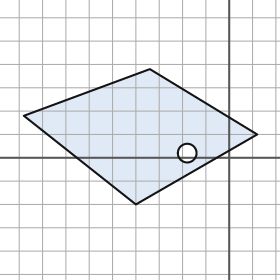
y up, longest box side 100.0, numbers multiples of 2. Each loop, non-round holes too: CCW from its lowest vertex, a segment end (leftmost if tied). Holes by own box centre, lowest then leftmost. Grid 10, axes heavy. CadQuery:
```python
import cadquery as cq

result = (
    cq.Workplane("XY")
    .moveTo(-40.0, -20.0)
    .lineTo(12.0, 10.0)
    .lineTo(-34.0, 38.0)
    .lineTo(-88.0, 18.0)
    .close()
    .moveTo(-18.0, 2.0)
    .circle(4.0)
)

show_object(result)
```